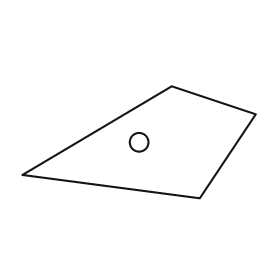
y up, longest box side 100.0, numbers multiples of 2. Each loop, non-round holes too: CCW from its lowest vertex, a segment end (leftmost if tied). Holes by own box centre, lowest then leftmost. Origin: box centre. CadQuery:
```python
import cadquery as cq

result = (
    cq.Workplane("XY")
    .moveTo(26.0, -24.0)
    .lineTo(50.0, 12.0)
    .lineTo(14.0, 24.0)
    .lineTo(-50.0, -14.0)
    .close()
    .moveTo(0.0, 0.0)
    .circle(4.0)
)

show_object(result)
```